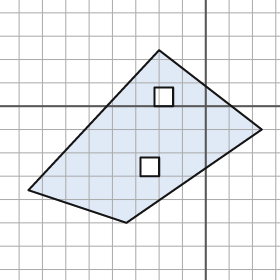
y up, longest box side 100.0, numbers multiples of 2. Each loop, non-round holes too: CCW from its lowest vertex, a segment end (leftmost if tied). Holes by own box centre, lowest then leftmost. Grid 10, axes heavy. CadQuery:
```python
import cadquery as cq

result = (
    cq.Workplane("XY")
    .moveTo(-34.0, -50.0)
    .lineTo(24.0, -10.0)
    .lineTo(-20.0, 24.0)
    .lineTo(-76.0, -36.0)
    .close()
    .moveTo(-28.0, -30.0)
    .lineTo(-20.0, -30.0)
    .lineTo(-20.0, -22.0)
    .lineTo(-28.0, -22.0)
    .close()
    .moveTo(-22.0, 0.0)
    .lineTo(-14.0, 0.0)
    .lineTo(-14.0, 8.0)
    .lineTo(-22.0, 8.0)
    .close()
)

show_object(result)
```